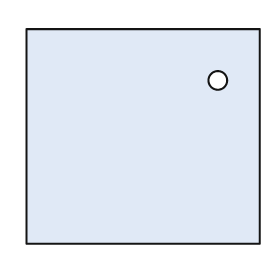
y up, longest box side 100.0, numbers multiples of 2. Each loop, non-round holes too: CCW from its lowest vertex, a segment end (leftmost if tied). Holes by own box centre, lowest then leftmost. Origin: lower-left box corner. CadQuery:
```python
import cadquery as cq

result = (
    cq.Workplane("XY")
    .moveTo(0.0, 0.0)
    .lineTo(100.0, 0.0)
    .lineTo(100.0, 92.0)
    .lineTo(0.0, 92.0)
    .close()
    .moveTo(82.0, 70.0)
    .circle(4.0)
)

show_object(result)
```